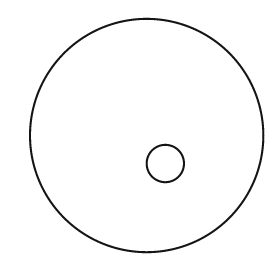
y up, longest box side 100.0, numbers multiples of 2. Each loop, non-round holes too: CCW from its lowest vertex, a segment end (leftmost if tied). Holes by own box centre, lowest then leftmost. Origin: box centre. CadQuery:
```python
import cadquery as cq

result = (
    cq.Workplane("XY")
    .moveTo(0.0, 0.0)
    .circle(50.0)
    .moveTo(8.0, -12.0)
    .circle(8.0)
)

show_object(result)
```